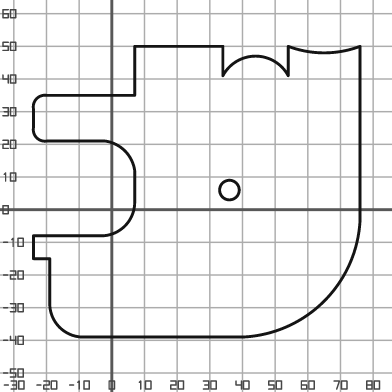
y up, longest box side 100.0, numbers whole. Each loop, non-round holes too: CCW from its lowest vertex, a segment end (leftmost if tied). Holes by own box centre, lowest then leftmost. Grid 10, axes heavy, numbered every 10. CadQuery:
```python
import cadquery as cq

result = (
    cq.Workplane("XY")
    .moveTo(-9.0, -39.0)
    .lineTo(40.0, -39.0)
    .threePointArc((65.0, -28.0), (76.0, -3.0))
    .lineTo(76.0, 50.0)
    .threePointArc((65.0, 48.0), (54.0, 50.0))
    .lineTo(54.0, 41.0)
    .threePointArc((44.0, 47.0), (34.0, 41.0))
    .lineTo(34.0, 50.0)
    .lineTo(7.0, 50.0)
    .lineTo(7.0, 35.0)
    .lineTo(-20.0, 35.0)
    .threePointArc((-23.0, 34.0), (-24.0, 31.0))
    .lineTo(-24.0, 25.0)
    .threePointArc((-23.0, 22.0), (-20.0, 21.0))
    .lineTo(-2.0, 21.0)
    .threePointArc((4.0, 18.0), (7.0, 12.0))
    .lineTo(7.0, 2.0)
    .threePointArc((4.0, -5.0), (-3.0, -8.0))
    .lineTo(-24.0, -8.0)
    .lineTo(-24.0, -15.0)
    .lineTo(-19.0, -15.0)
    .lineTo(-19.0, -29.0)
    .threePointArc((-16.0, -36.0), (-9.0, -39.0))
    .close()
    .moveTo(36.0, 6.0)
    .circle(3.0)
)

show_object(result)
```